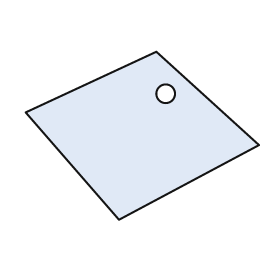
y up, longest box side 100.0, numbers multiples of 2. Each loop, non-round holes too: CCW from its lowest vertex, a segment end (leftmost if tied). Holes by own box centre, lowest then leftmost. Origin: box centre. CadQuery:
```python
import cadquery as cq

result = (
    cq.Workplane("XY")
    .moveTo(-10.0, -36.0)
    .lineTo(50.0, -4.0)
    .lineTo(6.0, 36.0)
    .lineTo(-50.0, 10.0)
    .close()
    .moveTo(10.0, 18.0)
    .circle(4.0)
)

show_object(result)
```